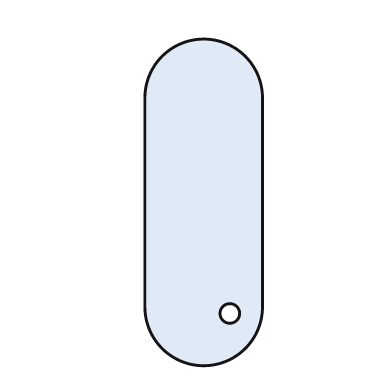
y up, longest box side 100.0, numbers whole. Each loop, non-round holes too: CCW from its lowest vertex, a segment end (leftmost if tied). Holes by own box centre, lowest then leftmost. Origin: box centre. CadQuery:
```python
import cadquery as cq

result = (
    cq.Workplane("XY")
    .moveTo(-18.0, -32.0)
    .threePointArc((0.0, -50.0), (18.0, -32.0))
    .lineTo(18.0, 32.0)
    .threePointArc((0.0, 50.0), (-18.0, 32.0))
    .close()
    .moveTo(8.0, -34.0)
    .circle(3.0)
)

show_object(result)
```